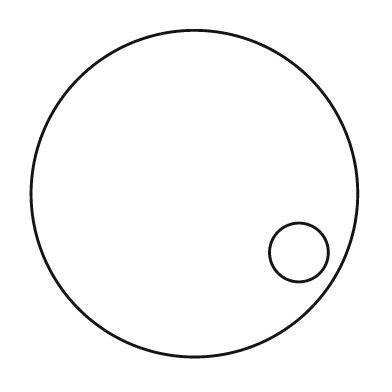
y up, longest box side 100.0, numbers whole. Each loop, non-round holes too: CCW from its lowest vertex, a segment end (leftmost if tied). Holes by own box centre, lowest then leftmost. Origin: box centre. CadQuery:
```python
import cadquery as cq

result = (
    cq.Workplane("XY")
    .moveTo(0.0, 0.0)
    .circle(50.0)
    .moveTo(32.0, -18.0)
    .circle(9.0)
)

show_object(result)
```